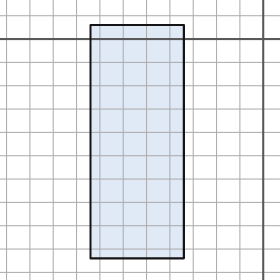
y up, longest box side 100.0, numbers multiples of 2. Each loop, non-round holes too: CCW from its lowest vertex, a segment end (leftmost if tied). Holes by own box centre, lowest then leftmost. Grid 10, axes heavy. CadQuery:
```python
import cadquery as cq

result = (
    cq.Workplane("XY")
    .moveTo(-74.0, -94.0)
    .lineTo(-34.0, -94.0)
    .lineTo(-34.0, 6.0)
    .lineTo(-74.0, 6.0)
    .close()
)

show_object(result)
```